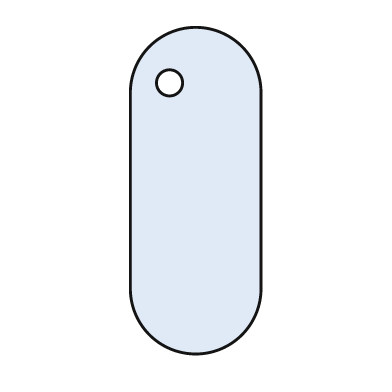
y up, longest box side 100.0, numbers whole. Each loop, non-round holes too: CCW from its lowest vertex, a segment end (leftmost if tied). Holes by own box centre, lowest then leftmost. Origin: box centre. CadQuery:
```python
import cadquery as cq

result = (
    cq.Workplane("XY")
    .moveTo(-20.0, -30.0)
    .threePointArc((0.0, -50.0), (20.0, -30.0))
    .lineTo(20.0, 30.0)
    .threePointArc((0.0, 50.0), (-20.0, 30.0))
    .close()
    .moveTo(-8.0, 33.0)
    .circle(4.0)
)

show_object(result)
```